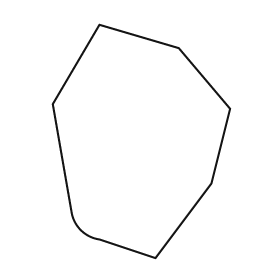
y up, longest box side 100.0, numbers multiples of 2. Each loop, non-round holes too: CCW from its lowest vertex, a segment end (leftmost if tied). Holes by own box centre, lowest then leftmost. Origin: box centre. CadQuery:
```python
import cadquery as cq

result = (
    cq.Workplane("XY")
    .moveTo(6.0, -50.0)
    .lineTo(30.0, -18.0)
    .lineTo(38.0, 14.0)
    .lineTo(16.0, 40.0)
    .lineTo(-18.0, 50.0)
    .lineTo(-38.0, 16.0)
    .lineTo(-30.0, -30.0)
    .threePointArc((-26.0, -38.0), (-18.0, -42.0))
    .close()
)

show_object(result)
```